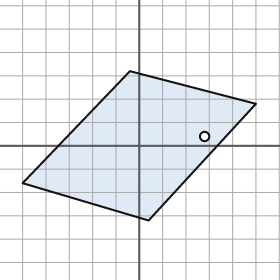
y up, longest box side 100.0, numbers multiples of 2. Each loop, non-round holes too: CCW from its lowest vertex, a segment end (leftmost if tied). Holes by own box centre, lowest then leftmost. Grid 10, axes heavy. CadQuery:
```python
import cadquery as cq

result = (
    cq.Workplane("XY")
    .moveTo(4.0, -32.0)
    .lineTo(50.0, 18.0)
    .lineTo(-4.0, 32.0)
    .lineTo(-50.0, -16.0)
    .close()
    .moveTo(28.0, 4.0)
    .circle(2.0)
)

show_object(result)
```